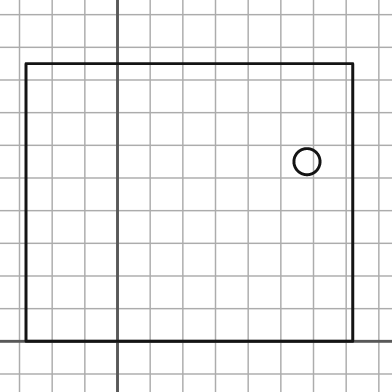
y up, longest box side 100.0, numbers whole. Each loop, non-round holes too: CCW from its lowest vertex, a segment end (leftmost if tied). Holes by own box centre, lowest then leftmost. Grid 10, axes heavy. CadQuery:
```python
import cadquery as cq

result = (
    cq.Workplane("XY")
    .moveTo(-28.0, 0.0)
    .lineTo(72.0, 0.0)
    .lineTo(72.0, 85.0)
    .lineTo(-28.0, 85.0)
    .close()
    .moveTo(58.0, 55.0)
    .circle(4.0)
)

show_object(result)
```